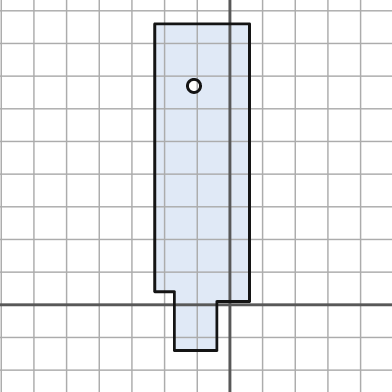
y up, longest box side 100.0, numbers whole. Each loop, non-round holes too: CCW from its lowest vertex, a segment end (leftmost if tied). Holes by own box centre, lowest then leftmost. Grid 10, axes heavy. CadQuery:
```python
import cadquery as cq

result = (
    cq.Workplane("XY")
    .moveTo(-17.0, -14.0)
    .lineTo(-4.0, -14.0)
    .lineTo(-4.0, 1.0)
    .lineTo(6.0, 1.0)
    .lineTo(6.0, 86.0)
    .lineTo(-23.0, 86.0)
    .lineTo(-23.0, 4.0)
    .lineTo(-17.0, 4.0)
    .close()
    .moveTo(-11.0, 67.0)
    .circle(2.0)
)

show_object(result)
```